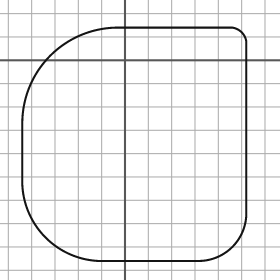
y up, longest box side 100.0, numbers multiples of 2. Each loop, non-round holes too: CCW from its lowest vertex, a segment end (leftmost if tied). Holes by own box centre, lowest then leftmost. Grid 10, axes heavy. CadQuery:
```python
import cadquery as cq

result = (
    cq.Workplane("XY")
    .moveTo(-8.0, -86.0)
    .lineTo(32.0, -86.0)
    .threePointArc((46.0, -80.0), (52.0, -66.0))
    .lineTo(52.0, 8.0)
    .threePointArc((50.0, 12.0), (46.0, 14.0))
    .lineTo(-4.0, 14.0)
    .threePointArc((-32.0, 2.0), (-44.0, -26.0))
    .lineTo(-44.0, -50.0)
    .threePointArc((-34.0, -76.0), (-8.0, -86.0))
    .close()
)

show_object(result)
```